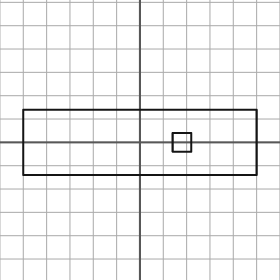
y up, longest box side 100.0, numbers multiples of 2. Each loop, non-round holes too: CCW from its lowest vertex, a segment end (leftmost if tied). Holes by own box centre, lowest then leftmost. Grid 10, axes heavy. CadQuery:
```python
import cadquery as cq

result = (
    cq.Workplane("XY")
    .moveTo(-50.0, -14.0)
    .lineTo(50.0, -14.0)
    .lineTo(50.0, 14.0)
    .lineTo(-50.0, 14.0)
    .close()
    .moveTo(14.0, -4.0)
    .lineTo(22.0, -4.0)
    .lineTo(22.0, 4.0)
    .lineTo(14.0, 4.0)
    .close()
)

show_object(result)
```